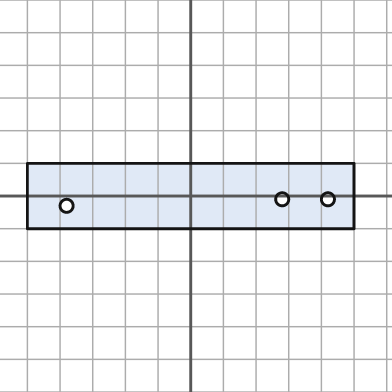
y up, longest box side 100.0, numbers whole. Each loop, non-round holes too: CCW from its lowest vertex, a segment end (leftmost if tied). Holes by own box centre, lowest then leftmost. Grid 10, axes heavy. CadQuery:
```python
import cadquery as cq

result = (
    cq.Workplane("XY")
    .moveTo(-50.0, -10.0)
    .lineTo(50.0, -10.0)
    .lineTo(50.0, 10.0)
    .lineTo(-50.0, 10.0)
    .close()
    .moveTo(-38.0, -3.0)
    .circle(2.0)
    .moveTo(28.0, -1.0)
    .circle(2.0)
    .moveTo(42.0, -1.0)
    .circle(2.0)
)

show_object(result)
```